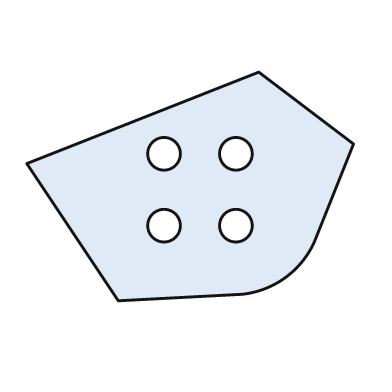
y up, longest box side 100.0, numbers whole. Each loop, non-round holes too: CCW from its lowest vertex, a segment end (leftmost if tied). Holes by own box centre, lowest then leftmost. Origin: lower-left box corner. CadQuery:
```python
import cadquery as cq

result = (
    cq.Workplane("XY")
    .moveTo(28.0, 0.0)
    .lineTo(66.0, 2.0)
    .threePointArc((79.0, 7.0), (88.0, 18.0))
    .lineTo(100.0, 48.0)
    .lineTo(71.0, 70.0)
    .lineTo(0.0, 42.0)
    .close()
    .moveTo(42.0, 23.0)
    .circle(5.0)
    .moveTo(64.0, 23.0)
    .circle(5.0)
    .moveTo(42.0, 45.0)
    .circle(5.0)
    .moveTo(64.0, 45.0)
    .circle(5.0)
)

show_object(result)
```